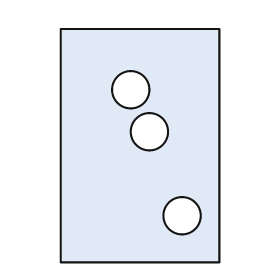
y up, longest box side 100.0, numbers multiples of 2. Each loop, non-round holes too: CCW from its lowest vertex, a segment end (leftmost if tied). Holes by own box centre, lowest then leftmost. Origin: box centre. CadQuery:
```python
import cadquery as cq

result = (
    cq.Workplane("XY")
    .moveTo(-34.0, -50.0)
    .lineTo(34.0, -50.0)
    .lineTo(34.0, 50.0)
    .lineTo(-34.0, 50.0)
    .close()
    .moveTo(18.0, -30.0)
    .circle(8.0)
    .moveTo(4.0, 6.0)
    .circle(8.0)
    .moveTo(-4.0, 24.0)
    .circle(8.0)
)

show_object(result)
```